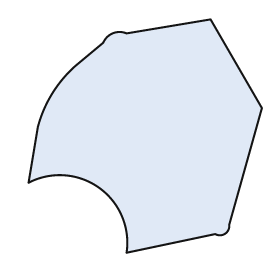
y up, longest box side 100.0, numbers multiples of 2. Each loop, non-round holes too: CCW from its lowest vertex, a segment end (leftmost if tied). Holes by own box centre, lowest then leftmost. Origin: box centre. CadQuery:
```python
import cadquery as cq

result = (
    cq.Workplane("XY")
    .moveTo(-8.0, -50.0)
    .lineTo(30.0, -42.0)
    .threePointArc((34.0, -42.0), (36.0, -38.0))
    .lineTo(50.0, 12.0)
    .lineTo(28.0, 50.0)
    .lineTo(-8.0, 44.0)
    .threePointArc((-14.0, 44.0), (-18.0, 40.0))
    .lineTo(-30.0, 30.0)
    .threePointArc((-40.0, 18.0), (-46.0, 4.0))
    .lineTo(-50.0, -20.0)
    .threePointArc((-20.0, -22.0), (-8.0, -50.0))
    .close()
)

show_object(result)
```